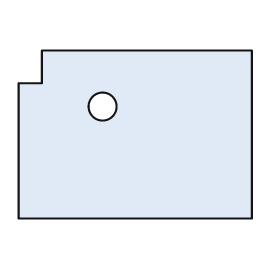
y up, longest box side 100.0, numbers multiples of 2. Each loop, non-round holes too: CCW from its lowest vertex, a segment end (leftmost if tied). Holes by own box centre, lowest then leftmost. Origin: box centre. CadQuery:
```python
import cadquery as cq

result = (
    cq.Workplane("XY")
    .moveTo(-50.0, -36.0)
    .lineTo(50.0, -36.0)
    .lineTo(50.0, 36.0)
    .lineTo(-40.0, 36.0)
    .lineTo(-40.0, 22.0)
    .lineTo(-50.0, 22.0)
    .close()
    .moveTo(-14.0, 12.0)
    .circle(6.0)
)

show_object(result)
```